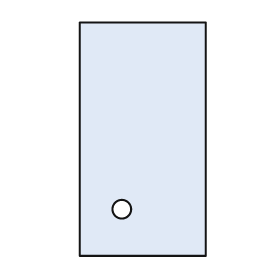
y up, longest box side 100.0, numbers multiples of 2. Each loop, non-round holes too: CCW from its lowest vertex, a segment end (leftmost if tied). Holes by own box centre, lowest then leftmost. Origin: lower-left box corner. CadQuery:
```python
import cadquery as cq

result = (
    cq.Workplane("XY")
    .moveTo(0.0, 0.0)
    .lineTo(54.0, 0.0)
    .lineTo(54.0, 100.0)
    .lineTo(0.0, 100.0)
    .close()
    .moveTo(18.0, 20.0)
    .circle(4.0)
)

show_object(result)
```